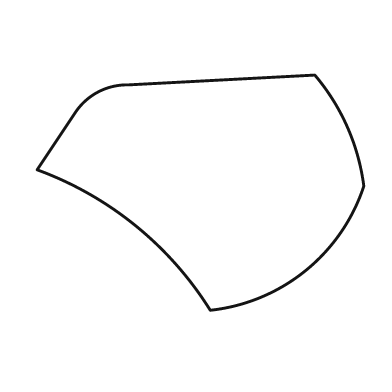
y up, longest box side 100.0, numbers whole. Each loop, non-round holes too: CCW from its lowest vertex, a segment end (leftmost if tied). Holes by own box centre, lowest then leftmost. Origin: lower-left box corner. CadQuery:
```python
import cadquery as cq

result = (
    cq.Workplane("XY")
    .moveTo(53.0, 0.0)
    .threePointArc((82.0, 12.0), (100.0, 38.0))
    .threePointArc((95.0, 56.0), (85.0, 72.0))
    .lineTo(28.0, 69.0)
    .threePointArc((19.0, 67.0), (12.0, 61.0))
    .lineTo(0.0, 43.0)
    .threePointArc((30.0, 26.0), (53.0, 0.0))
    .close()
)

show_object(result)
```